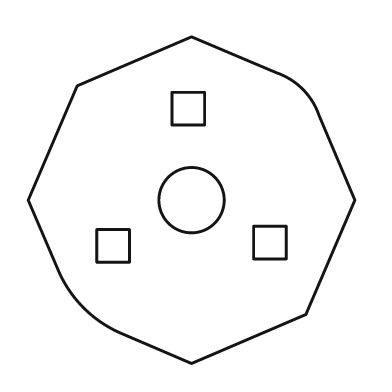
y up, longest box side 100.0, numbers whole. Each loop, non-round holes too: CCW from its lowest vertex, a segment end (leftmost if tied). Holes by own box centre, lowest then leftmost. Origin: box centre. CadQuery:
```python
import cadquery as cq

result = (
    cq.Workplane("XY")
    .moveTo(0.0, -50.0)
    .lineTo(35.0, -35.0)
    .lineTo(50.0, 0.0)
    .lineTo(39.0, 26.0)
    .threePointArc((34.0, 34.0), (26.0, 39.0))
    .lineTo(0.0, 50.0)
    .lineTo(-35.0, 35.0)
    .lineTo(-50.0, 0.0)
    .lineTo(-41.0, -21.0)
    .threePointArc((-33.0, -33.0), (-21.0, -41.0))
    .close()
    .moveTo(-29.0, -19.0)
    .lineTo(-19.0, -19.0)
    .lineTo(-19.0, -9.0)
    .lineTo(-29.0, -9.0)
    .close()
    .moveTo(19.0, -18.0)
    .lineTo(29.0, -18.0)
    .lineTo(29.0, -8.0)
    .lineTo(19.0, -8.0)
    .close()
    .moveTo(0.0, 0.0)
    .circle(10.0)
    .moveTo(-6.0, 23.0)
    .lineTo(4.0, 23.0)
    .lineTo(4.0, 33.0)
    .lineTo(-6.0, 33.0)
    .close()
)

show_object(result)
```